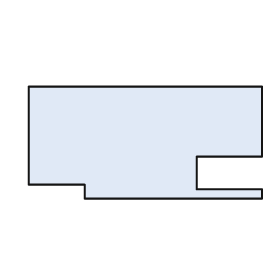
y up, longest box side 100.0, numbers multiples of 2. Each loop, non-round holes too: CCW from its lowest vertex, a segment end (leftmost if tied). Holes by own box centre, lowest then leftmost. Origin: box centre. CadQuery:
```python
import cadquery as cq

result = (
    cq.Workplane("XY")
    .moveTo(-26.0, -24.0)
    .lineTo(50.0, -24.0)
    .lineTo(50.0, -20.0)
    .lineTo(22.0, -20.0)
    .lineTo(22.0, -6.0)
    .lineTo(50.0, -6.0)
    .lineTo(50.0, 24.0)
    .lineTo(-50.0, 24.0)
    .lineTo(-50.0, -18.0)
    .lineTo(-26.0, -18.0)
    .close()
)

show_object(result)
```